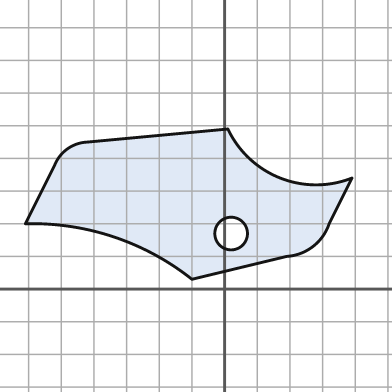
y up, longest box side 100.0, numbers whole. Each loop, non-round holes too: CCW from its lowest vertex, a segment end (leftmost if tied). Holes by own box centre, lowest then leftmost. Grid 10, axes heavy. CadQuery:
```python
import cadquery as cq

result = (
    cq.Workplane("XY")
    .moveTo(-10.0, 3.0)
    .lineTo(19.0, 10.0)
    .threePointArc((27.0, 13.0), (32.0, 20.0))
    .lineTo(39.0, 34.0)
    .threePointArc((17.0, 34.0), (1.0, 49.0))
    .lineTo(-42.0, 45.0)
    .threePointArc((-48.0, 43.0), (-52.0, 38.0))
    .lineTo(-61.0, 20.0)
    .threePointArc((-34.0, 16.0), (-10.0, 3.0))
    .close()
    .moveTo(2.0, 17.0)
    .circle(5.0)
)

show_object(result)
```